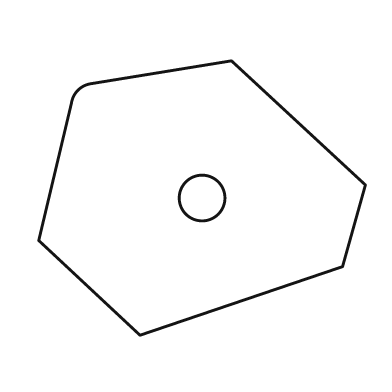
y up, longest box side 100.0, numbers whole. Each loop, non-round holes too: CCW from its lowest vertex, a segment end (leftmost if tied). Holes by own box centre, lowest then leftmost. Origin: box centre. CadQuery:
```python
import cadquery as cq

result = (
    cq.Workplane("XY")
    .moveTo(-19.0, -42.0)
    .lineTo(43.0, -21.0)
    .lineTo(50.0, 4.0)
    .lineTo(9.0, 42.0)
    .lineTo(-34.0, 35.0)
    .threePointArc((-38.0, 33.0), (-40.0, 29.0))
    .lineTo(-50.0, -13.0)
    .close()
    .moveTo(0.0, 0.0)
    .circle(7.0)
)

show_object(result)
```